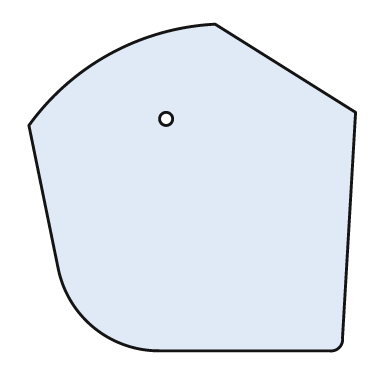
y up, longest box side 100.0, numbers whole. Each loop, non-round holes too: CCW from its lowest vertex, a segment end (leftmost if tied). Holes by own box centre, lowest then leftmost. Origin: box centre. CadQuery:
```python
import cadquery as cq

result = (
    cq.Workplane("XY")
    .moveTo(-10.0, -50.0)
    .lineTo(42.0, -50.0)
    .threePointArc((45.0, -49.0), (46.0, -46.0))
    .lineTo(50.0, 23.0)
    .lineTo(7.0, 50.0)
    .threePointArc((-25.0, 41.0), (-50.0, 19.0))
    .lineTo(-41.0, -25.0)
    .threePointArc((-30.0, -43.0), (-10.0, -50.0))
    .close()
    .moveTo(-8.0, 21.0)
    .circle(2.0)
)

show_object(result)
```